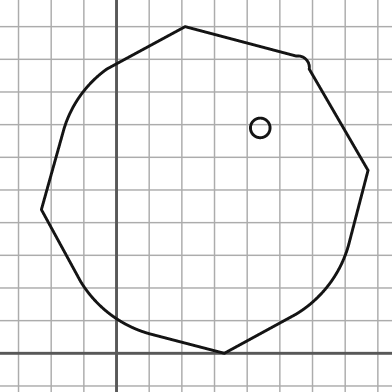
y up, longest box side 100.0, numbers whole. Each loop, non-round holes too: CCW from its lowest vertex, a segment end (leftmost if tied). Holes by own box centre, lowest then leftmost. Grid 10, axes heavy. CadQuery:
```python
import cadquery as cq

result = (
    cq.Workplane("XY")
    .moveTo(33.0, 0.0)
    .lineTo(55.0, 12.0)
    .threePointArc((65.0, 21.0), (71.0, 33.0))
    .lineTo(77.0, 56.0)
    .lineTo(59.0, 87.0)
    .threePointArc((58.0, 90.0), (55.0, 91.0))
    .lineTo(21.0, 100.0)
    .lineTo(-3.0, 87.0)
    .threePointArc((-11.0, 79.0), (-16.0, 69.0))
    .lineTo(-23.0, 44.0)
    .lineTo(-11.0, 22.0)
    .threePointArc((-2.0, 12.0), (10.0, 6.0))
    .close()
    .moveTo(44.0, 69.0)
    .circle(3.0)
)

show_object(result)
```